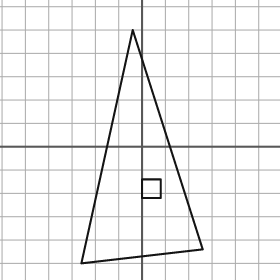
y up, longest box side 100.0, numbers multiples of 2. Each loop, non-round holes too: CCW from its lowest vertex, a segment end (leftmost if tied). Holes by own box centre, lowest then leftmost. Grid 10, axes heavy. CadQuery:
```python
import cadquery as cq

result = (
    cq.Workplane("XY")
    .moveTo(-26.0, -50.0)
    .lineTo(26.0, -44.0)
    .lineTo(-4.0, 50.0)
    .close()
    .moveTo(0.0, -22.0)
    .lineTo(8.0, -22.0)
    .lineTo(8.0, -14.0)
    .lineTo(0.0, -14.0)
    .close()
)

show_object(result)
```